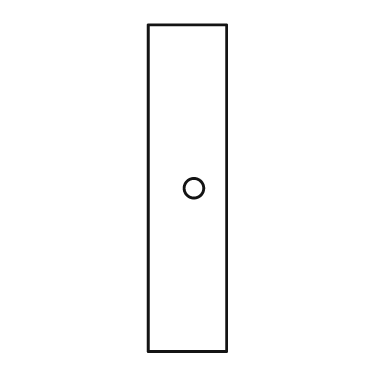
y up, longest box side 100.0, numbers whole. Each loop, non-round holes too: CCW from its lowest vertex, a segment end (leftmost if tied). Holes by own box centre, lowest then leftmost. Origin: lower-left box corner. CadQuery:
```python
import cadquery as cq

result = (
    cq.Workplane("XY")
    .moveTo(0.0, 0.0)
    .lineTo(24.0, 0.0)
    .lineTo(24.0, 100.0)
    .lineTo(0.0, 100.0)
    .close()
    .moveTo(14.0, 50.0)
    .circle(3.0)
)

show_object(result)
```